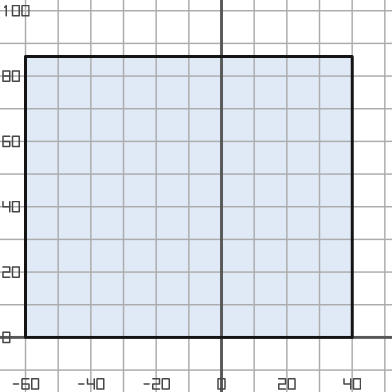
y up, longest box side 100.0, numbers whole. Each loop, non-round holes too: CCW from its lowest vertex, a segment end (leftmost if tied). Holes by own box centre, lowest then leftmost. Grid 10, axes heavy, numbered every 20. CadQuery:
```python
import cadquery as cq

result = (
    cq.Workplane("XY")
    .moveTo(-60.0, 0.0)
    .lineTo(40.0, 0.0)
    .lineTo(40.0, 86.0)
    .lineTo(-60.0, 86.0)
    .close()
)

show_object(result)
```